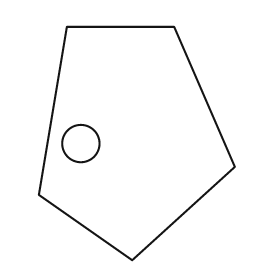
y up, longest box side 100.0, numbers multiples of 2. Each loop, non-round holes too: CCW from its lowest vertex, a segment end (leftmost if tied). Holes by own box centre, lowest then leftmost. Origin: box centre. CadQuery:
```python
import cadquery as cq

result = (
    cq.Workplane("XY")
    .moveTo(-2.0, -50.0)
    .lineTo(42.0, -10.0)
    .lineTo(16.0, 50.0)
    .lineTo(-30.0, 50.0)
    .lineTo(-42.0, -22.0)
    .close()
    .moveTo(-24.0, 0.0)
    .circle(8.0)
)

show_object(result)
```